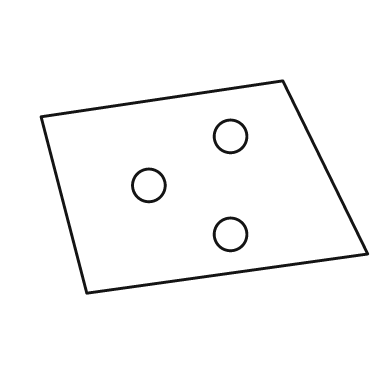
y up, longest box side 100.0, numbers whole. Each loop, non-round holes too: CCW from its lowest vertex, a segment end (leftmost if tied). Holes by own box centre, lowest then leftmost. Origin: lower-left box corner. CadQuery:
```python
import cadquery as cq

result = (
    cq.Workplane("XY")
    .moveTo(14.0, 0.0)
    .lineTo(100.0, 12.0)
    .lineTo(74.0, 65.0)
    .lineTo(0.0, 54.0)
    .close()
    .moveTo(58.0, 18.0)
    .circle(5.0)
    .moveTo(33.0, 33.0)
    .circle(5.0)
    .moveTo(58.0, 48.0)
    .circle(5.0)
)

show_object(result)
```